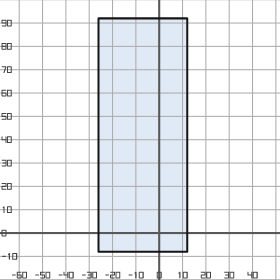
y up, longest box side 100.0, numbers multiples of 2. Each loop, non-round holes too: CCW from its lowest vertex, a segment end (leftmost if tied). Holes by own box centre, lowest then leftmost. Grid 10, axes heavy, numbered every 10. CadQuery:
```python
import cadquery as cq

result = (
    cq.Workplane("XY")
    .moveTo(-26.0, -8.0)
    .lineTo(12.0, -8.0)
    .lineTo(12.0, 92.0)
    .lineTo(-26.0, 92.0)
    .close()
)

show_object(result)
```